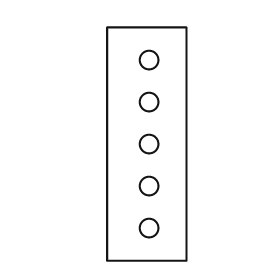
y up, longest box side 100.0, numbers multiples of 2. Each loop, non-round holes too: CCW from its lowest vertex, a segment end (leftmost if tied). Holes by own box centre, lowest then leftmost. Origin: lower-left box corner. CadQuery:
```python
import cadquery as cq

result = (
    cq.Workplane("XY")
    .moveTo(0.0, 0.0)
    .lineTo(34.0, 0.0)
    .lineTo(34.0, 100.0)
    .lineTo(0.0, 100.0)
    .close()
    .moveTo(18.0, 14.0)
    .circle(4.0)
    .moveTo(18.0, 32.0)
    .circle(4.0)
    .moveTo(18.0, 50.0)
    .circle(4.0)
    .moveTo(18.0, 68.0)
    .circle(4.0)
    .moveTo(18.0, 86.0)
    .circle(4.0)
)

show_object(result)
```